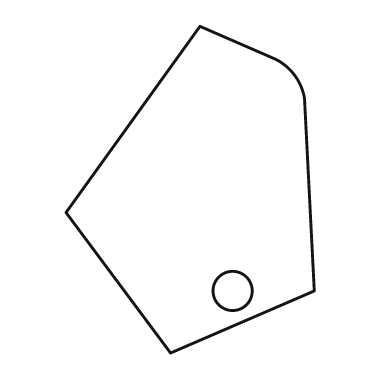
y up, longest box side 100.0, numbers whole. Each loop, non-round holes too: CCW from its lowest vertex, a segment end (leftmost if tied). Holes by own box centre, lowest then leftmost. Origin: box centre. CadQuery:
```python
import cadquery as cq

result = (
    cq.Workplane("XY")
    .moveTo(-6.0, -50.0)
    .lineTo(38.0, -31.0)
    .lineTo(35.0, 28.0)
    .threePointArc((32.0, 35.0), (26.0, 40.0))
    .lineTo(3.0, 50.0)
    .lineTo(-38.0, -7.0)
    .close()
    .moveTo(13.0, -31.0)
    .circle(6.0)
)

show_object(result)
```